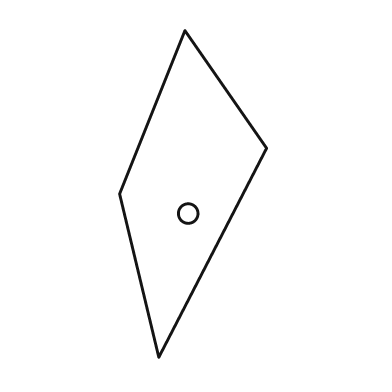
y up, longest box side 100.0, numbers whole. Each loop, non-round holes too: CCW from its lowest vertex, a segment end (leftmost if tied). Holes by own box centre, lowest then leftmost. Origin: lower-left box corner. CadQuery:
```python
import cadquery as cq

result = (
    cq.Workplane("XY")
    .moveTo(12.0, 0.0)
    .lineTo(45.0, 64.0)
    .lineTo(20.0, 100.0)
    .lineTo(0.0, 50.0)
    .close()
    .moveTo(21.0, 44.0)
    .circle(3.0)
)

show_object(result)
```